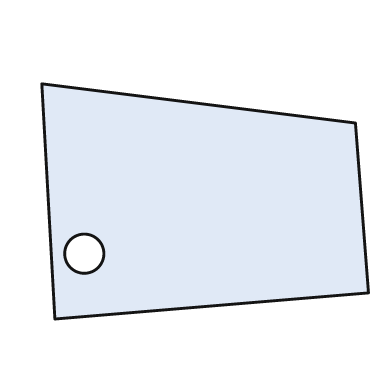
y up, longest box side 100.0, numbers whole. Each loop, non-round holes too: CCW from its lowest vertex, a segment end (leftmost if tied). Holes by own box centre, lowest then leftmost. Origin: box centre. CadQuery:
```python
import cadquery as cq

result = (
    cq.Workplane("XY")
    .moveTo(-46.0, -36.0)
    .lineTo(50.0, -28.0)
    .lineTo(46.0, 24.0)
    .lineTo(-50.0, 36.0)
    .close()
    .moveTo(-37.0, -16.0)
    .circle(6.0)
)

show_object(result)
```